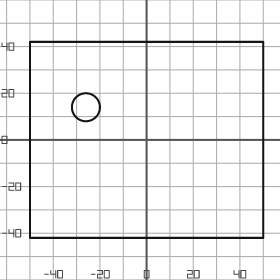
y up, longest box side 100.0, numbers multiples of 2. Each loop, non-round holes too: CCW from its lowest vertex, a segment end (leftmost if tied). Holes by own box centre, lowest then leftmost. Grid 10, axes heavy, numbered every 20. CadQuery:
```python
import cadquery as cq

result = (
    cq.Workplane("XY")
    .moveTo(-50.0, -42.0)
    .lineTo(50.0, -42.0)
    .lineTo(50.0, 42.0)
    .lineTo(-50.0, 42.0)
    .close()
    .moveTo(-26.0, 14.0)
    .circle(6.0)
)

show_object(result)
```